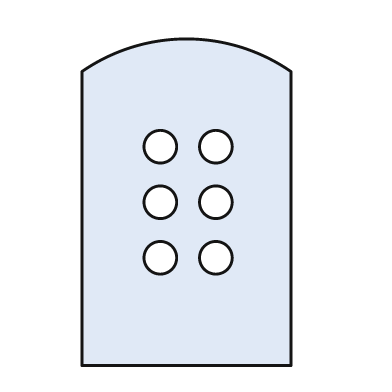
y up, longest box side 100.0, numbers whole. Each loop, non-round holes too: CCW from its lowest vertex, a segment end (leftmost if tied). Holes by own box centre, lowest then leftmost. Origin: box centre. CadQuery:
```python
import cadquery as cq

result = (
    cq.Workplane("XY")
    .moveTo(-32.0, -50.0)
    .lineTo(32.0, -50.0)
    .lineTo(32.0, 40.0)
    .threePointArc((0.0, 50.0), (-32.0, 40.0))
    .close()
    .moveTo(-8.0, -17.0)
    .circle(5.0)
    .moveTo(9.0, -17.0)
    .circle(5.0)
    .moveTo(-8.0, 0.0)
    .circle(5.0)
    .moveTo(9.0, 0.0)
    .circle(5.0)
    .moveTo(-8.0, 17.0)
    .circle(5.0)
    .moveTo(9.0, 17.0)
    .circle(5.0)
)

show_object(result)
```